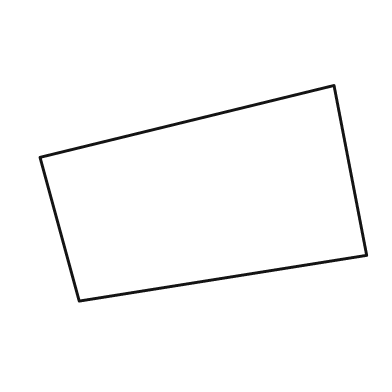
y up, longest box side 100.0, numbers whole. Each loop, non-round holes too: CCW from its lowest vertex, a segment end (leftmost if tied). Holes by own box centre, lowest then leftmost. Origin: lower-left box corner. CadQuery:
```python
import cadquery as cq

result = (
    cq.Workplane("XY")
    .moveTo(12.0, 0.0)
    .lineTo(100.0, 14.0)
    .lineTo(90.0, 66.0)
    .lineTo(0.0, 44.0)
    .close()
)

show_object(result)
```